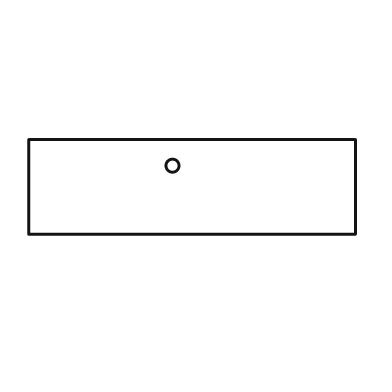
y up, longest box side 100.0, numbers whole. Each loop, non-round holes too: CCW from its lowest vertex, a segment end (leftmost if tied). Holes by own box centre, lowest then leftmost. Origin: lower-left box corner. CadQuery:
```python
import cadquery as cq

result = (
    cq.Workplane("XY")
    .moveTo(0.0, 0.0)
    .lineTo(100.0, 0.0)
    .lineTo(100.0, 29.0)
    .lineTo(0.0, 29.0)
    .close()
    .moveTo(44.0, 21.0)
    .circle(2.0)
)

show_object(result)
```